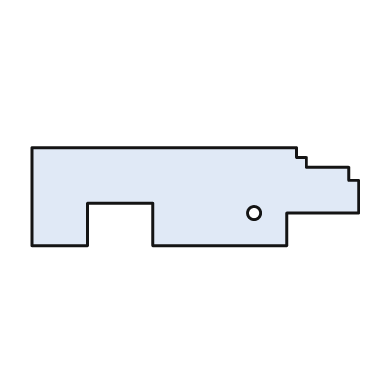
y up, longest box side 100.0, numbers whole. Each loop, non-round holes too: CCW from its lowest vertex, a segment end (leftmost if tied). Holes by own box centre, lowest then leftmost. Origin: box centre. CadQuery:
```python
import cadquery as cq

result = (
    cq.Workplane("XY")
    .moveTo(-50.0, -15.0)
    .lineTo(-33.0, -15.0)
    .lineTo(-33.0, -2.0)
    .lineTo(-13.0, -2.0)
    .lineTo(-13.0, -15.0)
    .lineTo(28.0, -15.0)
    .lineTo(28.0, -5.0)
    .lineTo(50.0, -5.0)
    .lineTo(50.0, 5.0)
    .lineTo(47.0, 5.0)
    .lineTo(47.0, 9.0)
    .lineTo(34.0, 9.0)
    .lineTo(34.0, 12.0)
    .lineTo(31.0, 12.0)
    .lineTo(31.0, 15.0)
    .lineTo(-50.0, 15.0)
    .close()
    .moveTo(18.0, -5.0)
    .circle(2.0)
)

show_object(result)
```